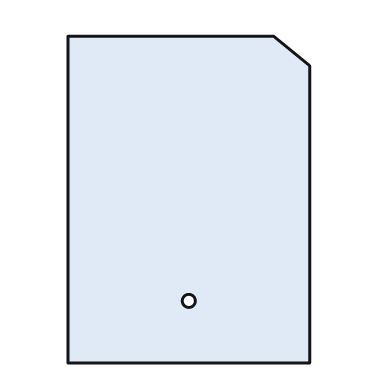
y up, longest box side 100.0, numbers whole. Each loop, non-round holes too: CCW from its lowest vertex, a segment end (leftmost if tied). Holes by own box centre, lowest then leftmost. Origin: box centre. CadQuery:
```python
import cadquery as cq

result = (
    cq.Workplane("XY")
    .moveTo(-37.0, -50.0)
    .lineTo(37.0, -50.0)
    .lineTo(37.0, 41.0)
    .lineTo(26.0, 50.0)
    .lineTo(-37.0, 50.0)
    .close()
    .moveTo(0.0, -31.0)
    .circle(2.0)
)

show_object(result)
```